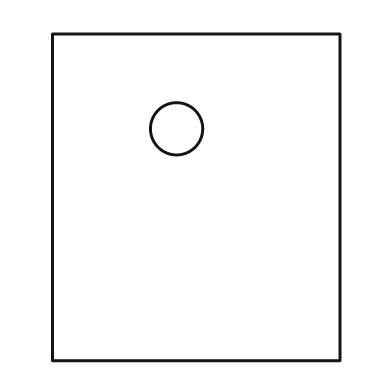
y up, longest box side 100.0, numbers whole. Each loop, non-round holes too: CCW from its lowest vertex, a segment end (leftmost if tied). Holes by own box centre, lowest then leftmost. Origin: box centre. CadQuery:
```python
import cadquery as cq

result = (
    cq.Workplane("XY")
    .moveTo(-44.0, -50.0)
    .lineTo(44.0, -50.0)
    .lineTo(44.0, 50.0)
    .lineTo(-44.0, 50.0)
    .close()
    .moveTo(-6.0, 21.0)
    .circle(8.0)
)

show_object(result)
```